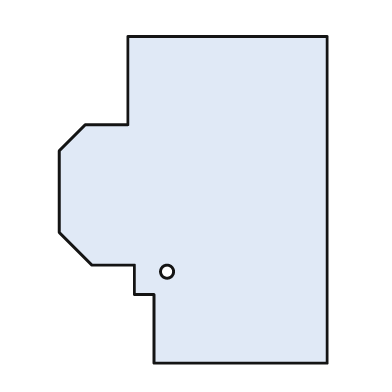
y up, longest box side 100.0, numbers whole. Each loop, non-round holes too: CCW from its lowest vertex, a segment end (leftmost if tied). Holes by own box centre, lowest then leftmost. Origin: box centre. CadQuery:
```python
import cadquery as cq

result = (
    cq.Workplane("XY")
    .moveTo(-12.0, -50.0)
    .lineTo(41.0, -50.0)
    .lineTo(41.0, 50.0)
    .lineTo(-20.0, 50.0)
    .lineTo(-20.0, 23.0)
    .lineTo(-33.0, 23.0)
    .lineTo(-41.0, 15.0)
    .lineTo(-41.0, -10.0)
    .lineTo(-31.0, -20.0)
    .lineTo(-18.0, -20.0)
    .lineTo(-18.0, -29.0)
    .lineTo(-12.0, -29.0)
    .close()
    .moveTo(-8.0, -22.0)
    .circle(2.0)
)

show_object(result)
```